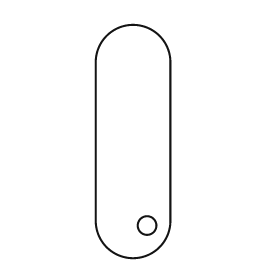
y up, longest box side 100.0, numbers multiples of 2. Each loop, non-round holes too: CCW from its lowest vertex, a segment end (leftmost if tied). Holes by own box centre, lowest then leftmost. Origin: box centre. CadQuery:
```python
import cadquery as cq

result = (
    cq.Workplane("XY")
    .moveTo(-16.0, -34.0)
    .threePointArc((0.0, -50.0), (16.0, -34.0))
    .lineTo(16.0, 34.0)
    .threePointArc((0.0, 50.0), (-16.0, 34.0))
    .close()
    .moveTo(6.0, -36.0)
    .circle(4.0)
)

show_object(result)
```